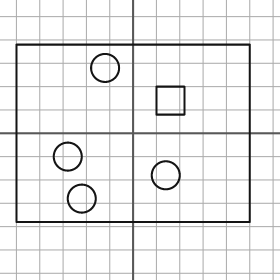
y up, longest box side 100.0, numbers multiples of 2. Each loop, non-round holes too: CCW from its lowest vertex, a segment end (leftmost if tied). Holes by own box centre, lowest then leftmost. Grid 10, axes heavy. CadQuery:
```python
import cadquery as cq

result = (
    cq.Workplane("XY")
    .moveTo(-50.0, -38.0)
    .lineTo(50.0, -38.0)
    .lineTo(50.0, 38.0)
    .lineTo(-50.0, 38.0)
    .close()
    .moveTo(-22.0, -28.0)
    .circle(6.0)
    .moveTo(14.0, -18.0)
    .circle(6.0)
    .moveTo(-28.0, -10.0)
    .circle(6.0)
    .moveTo(10.0, 8.0)
    .lineTo(22.0, 8.0)
    .lineTo(22.0, 20.0)
    .lineTo(10.0, 20.0)
    .close()
    .moveTo(-12.0, 28.0)
    .circle(6.0)
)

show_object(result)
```